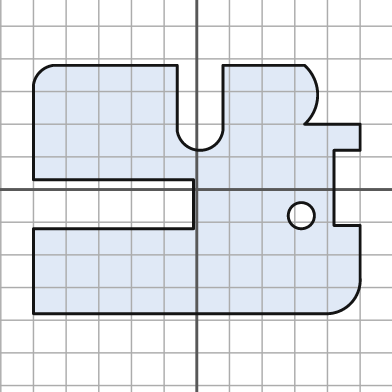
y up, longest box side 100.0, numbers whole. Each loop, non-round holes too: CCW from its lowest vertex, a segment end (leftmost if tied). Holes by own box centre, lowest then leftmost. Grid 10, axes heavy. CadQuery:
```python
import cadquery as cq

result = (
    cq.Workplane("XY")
    .moveTo(-50.0, -38.0)
    .lineTo(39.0, -38.0)
    .threePointArc((47.0, -35.0), (50.0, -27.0))
    .lineTo(50.0, -11.0)
    .lineTo(42.0, -11.0)
    .lineTo(42.0, 12.0)
    .lineTo(50.0, 12.0)
    .lineTo(50.0, 20.0)
    .lineTo(33.0, 20.0)
    .threePointArc((37.0, 29.0), (33.0, 38.0))
    .lineTo(8.0, 38.0)
    .lineTo(8.0, 18.0)
    .threePointArc((1.0, 12.0), (-6.0, 18.0))
    .lineTo(-6.0, 38.0)
    .lineTo(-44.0, 38.0)
    .threePointArc((-48.0, 36.0), (-50.0, 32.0))
    .lineTo(-50.0, 3.0)
    .lineTo(-1.0, 3.0)
    .lineTo(-1.0, -12.0)
    .lineTo(-50.0, -12.0)
    .close()
    .moveTo(32.0, -8.0)
    .circle(4.0)
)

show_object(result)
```